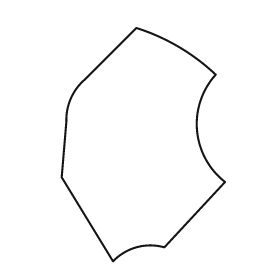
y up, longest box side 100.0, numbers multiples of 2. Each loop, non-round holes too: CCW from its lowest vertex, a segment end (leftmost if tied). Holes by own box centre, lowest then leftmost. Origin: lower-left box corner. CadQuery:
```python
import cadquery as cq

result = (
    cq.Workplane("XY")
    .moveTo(22.0, 0.0)
    .threePointArc((32.0, 6.0), (44.0, 6.0))
    .lineTo(70.0, 34.0)
    .threePointArc((58.0, 56.0), (66.0, 80.0))
    .threePointArc((50.0, 92.0), (32.0, 100.0))
    .lineTo(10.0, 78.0)
    .threePointArc((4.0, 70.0), (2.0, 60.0))
    .lineTo(0.0, 36.0)
    .close()
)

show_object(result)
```